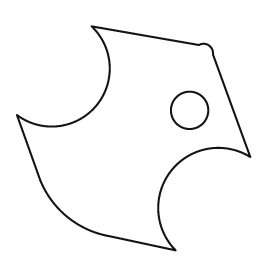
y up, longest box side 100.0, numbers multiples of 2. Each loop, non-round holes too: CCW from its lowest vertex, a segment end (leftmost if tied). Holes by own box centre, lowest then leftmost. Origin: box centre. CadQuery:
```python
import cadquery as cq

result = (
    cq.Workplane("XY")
    .moveTo(18.0, -48.0)
    .threePointArc((16.0, -14.0), (50.0, -8.0))
    .lineTo(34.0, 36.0)
    .threePointArc((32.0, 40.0), (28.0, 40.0))
    .lineTo(-18.0, 48.0)
    .threePointArc((-16.0, 14.0), (-50.0, 10.0))
    .lineTo(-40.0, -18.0)
    .threePointArc((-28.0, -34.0), (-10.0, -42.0))
    .close()
    .moveTo(24.0, 12.0)
    .circle(8.0)
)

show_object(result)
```